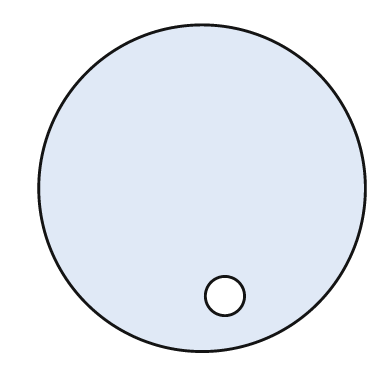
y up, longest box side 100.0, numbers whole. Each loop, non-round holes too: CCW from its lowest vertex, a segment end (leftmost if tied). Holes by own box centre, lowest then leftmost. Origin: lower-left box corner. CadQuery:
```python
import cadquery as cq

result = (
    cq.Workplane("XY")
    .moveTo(50.0, 50.0)
    .circle(50.0)
    .moveTo(57.0, 17.0)
    .circle(6.0)
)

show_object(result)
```